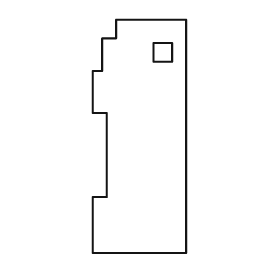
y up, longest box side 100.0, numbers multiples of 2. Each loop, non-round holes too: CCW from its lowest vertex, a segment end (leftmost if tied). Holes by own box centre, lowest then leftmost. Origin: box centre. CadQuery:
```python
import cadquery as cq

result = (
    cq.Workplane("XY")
    .moveTo(-20.0, -50.0)
    .lineTo(20.0, -50.0)
    .lineTo(20.0, 50.0)
    .lineTo(-10.0, 50.0)
    .lineTo(-10.0, 42.0)
    .lineTo(-16.0, 42.0)
    .lineTo(-16.0, 28.0)
    .lineTo(-20.0, 28.0)
    .lineTo(-20.0, 10.0)
    .lineTo(-14.0, 10.0)
    .lineTo(-14.0, -26.0)
    .lineTo(-20.0, -26.0)
    .close()
    .moveTo(6.0, 32.0)
    .lineTo(14.0, 32.0)
    .lineTo(14.0, 40.0)
    .lineTo(6.0, 40.0)
    .close()
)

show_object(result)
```